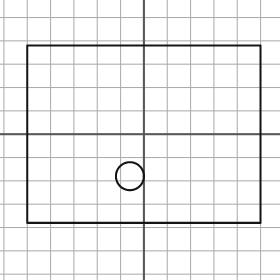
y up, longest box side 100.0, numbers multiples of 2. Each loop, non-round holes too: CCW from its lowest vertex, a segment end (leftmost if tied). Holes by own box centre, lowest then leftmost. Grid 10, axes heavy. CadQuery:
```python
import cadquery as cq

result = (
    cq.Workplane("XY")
    .moveTo(-50.0, -38.0)
    .lineTo(50.0, -38.0)
    .lineTo(50.0, 38.0)
    .lineTo(-50.0, 38.0)
    .close()
    .moveTo(-6.0, -18.0)
    .circle(6.0)
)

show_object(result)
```